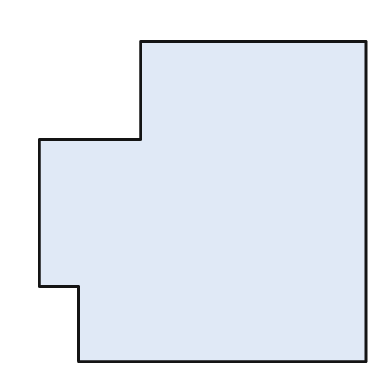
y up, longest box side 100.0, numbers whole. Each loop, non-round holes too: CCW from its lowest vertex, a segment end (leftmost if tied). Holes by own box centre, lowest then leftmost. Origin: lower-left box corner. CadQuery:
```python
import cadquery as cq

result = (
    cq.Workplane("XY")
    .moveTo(12.0, 0.0)
    .lineTo(100.0, 0.0)
    .lineTo(100.0, 98.0)
    .lineTo(31.0, 98.0)
    .lineTo(31.0, 68.0)
    .lineTo(0.0, 68.0)
    .lineTo(0.0, 23.0)
    .lineTo(12.0, 23.0)
    .close()
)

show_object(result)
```